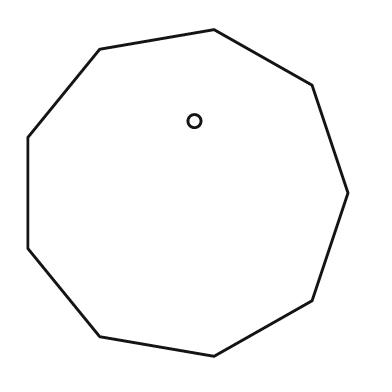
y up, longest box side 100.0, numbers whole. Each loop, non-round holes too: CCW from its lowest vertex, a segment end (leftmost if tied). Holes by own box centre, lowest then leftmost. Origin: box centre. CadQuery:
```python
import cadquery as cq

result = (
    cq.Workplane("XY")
    .moveTo(8.0, -50.0)
    .lineTo(38.0, -33.0)
    .lineTo(49.0, 0.0)
    .lineTo(38.0, 33.0)
    .lineTo(8.0, 50.0)
    .lineTo(-27.0, 44.0)
    .lineTo(-49.0, 17.0)
    .lineTo(-49.0, -17.0)
    .lineTo(-27.0, -44.0)
    .close()
    .moveTo(2.0, 22.0)
    .circle(2.0)
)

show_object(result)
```